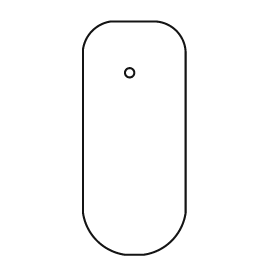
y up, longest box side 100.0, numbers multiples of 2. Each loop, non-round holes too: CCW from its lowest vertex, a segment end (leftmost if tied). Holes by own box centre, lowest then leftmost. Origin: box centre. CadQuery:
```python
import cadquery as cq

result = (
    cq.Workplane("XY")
    .moveTo(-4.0, -50.0)
    .lineTo(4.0, -50.0)
    .threePointArc((16.0, -44.0), (22.0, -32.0))
    .lineTo(22.0, 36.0)
    .threePointArc((18.0, 46.0), (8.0, 50.0))
    .lineTo(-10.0, 50.0)
    .threePointArc((-18.0, 46.0), (-22.0, 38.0))
    .lineTo(-22.0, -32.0)
    .threePointArc((-16.0, -44.0), (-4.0, -50.0))
    .close()
    .moveTo(-2.0, 28.0)
    .circle(2.0)
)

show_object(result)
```